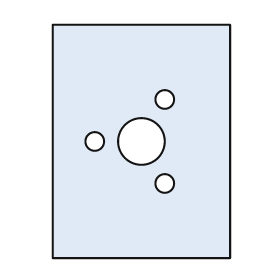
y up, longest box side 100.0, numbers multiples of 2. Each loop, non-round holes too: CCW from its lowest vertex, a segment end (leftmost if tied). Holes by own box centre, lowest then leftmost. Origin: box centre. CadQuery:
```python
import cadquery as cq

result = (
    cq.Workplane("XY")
    .moveTo(-38.0, -50.0)
    .lineTo(38.0, -50.0)
    .lineTo(38.0, 50.0)
    .lineTo(-38.0, 50.0)
    .close()
    .moveTo(10.0, -18.0)
    .circle(4.0)
    .moveTo(-20.0, 0.0)
    .circle(4.0)
    .moveTo(0.0, 0.0)
    .circle(10.0)
    .moveTo(10.0, 18.0)
    .circle(4.0)
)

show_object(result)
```